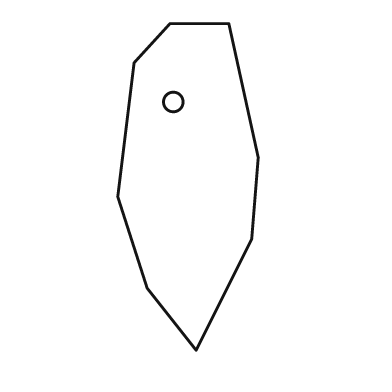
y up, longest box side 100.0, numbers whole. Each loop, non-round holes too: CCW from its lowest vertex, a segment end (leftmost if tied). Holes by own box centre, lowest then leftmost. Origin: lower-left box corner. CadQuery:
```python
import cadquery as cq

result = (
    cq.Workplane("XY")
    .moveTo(24.0, 0.0)
    .lineTo(41.0, 34.0)
    .lineTo(43.0, 59.0)
    .lineTo(34.0, 100.0)
    .lineTo(16.0, 100.0)
    .lineTo(5.0, 88.0)
    .lineTo(0.0, 47.0)
    .lineTo(9.0, 19.0)
    .close()
    .moveTo(17.0, 76.0)
    .circle(3.0)
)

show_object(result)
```